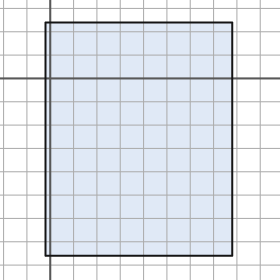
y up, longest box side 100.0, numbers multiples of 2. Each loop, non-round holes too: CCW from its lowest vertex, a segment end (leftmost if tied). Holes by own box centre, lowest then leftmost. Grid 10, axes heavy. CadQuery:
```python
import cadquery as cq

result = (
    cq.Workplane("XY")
    .moveTo(-2.0, -76.0)
    .lineTo(78.0, -76.0)
    .lineTo(78.0, 24.0)
    .lineTo(-2.0, 24.0)
    .close()
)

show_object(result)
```